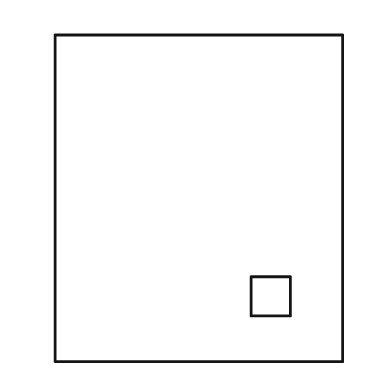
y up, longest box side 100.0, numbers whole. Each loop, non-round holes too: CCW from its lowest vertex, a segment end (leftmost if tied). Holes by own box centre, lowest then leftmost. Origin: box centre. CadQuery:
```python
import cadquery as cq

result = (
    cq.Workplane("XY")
    .moveTo(-44.0, -50.0)
    .lineTo(44.0, -50.0)
    .lineTo(44.0, 50.0)
    .lineTo(-44.0, 50.0)
    .close()
    .moveTo(16.0, -36.0)
    .lineTo(28.0, -36.0)
    .lineTo(28.0, -24.0)
    .lineTo(16.0, -24.0)
    .close()
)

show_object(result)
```